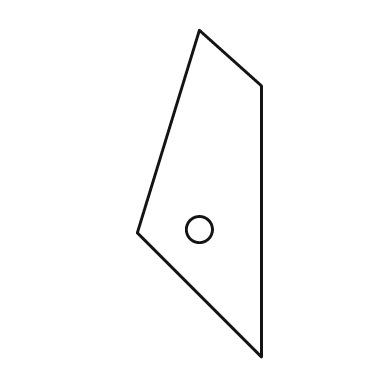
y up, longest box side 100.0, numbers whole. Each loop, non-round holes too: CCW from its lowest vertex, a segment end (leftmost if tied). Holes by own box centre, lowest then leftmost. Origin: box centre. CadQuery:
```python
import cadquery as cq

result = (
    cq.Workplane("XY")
    .moveTo(19.0, -50.0)
    .lineTo(19.0, 33.0)
    .lineTo(0.0, 50.0)
    .lineTo(-19.0, -12.0)
    .close()
    .moveTo(0.0, -11.0)
    .circle(4.0)
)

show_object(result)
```